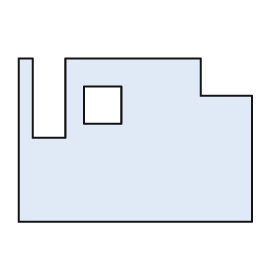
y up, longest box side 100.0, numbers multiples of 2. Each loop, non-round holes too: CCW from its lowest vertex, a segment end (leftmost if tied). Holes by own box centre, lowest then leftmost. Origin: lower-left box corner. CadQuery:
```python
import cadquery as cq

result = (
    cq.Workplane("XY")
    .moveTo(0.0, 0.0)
    .lineTo(100.0, 0.0)
    .lineTo(100.0, 54.0)
    .lineTo(78.0, 54.0)
    .lineTo(78.0, 70.0)
    .lineTo(20.0, 70.0)
    .lineTo(20.0, 36.0)
    .lineTo(6.0, 36.0)
    .lineTo(6.0, 70.0)
    .lineTo(0.0, 70.0)
    .close()
    .moveTo(28.0, 42.0)
    .lineTo(44.0, 42.0)
    .lineTo(44.0, 58.0)
    .lineTo(28.0, 58.0)
    .close()
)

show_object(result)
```